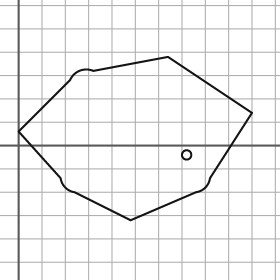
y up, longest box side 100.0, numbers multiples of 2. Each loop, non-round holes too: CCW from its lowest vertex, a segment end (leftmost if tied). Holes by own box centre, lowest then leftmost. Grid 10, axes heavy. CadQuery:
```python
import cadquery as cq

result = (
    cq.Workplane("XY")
    .moveTo(48.0, -32.0)
    .lineTo(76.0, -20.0)
    .threePointArc((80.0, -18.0), (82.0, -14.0))
    .lineTo(100.0, 14.0)
    .lineTo(64.0, 38.0)
    .lineTo(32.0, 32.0)
    .threePointArc((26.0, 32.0), (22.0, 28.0))
    .lineTo(0.0, 6.0)
    .lineTo(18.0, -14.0)
    .threePointArc((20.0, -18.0), (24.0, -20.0))
    .close()
    .moveTo(72.0, -4.0)
    .circle(2.0)
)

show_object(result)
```